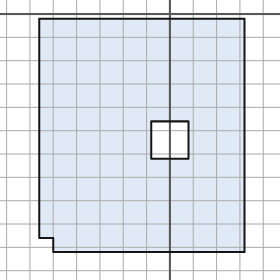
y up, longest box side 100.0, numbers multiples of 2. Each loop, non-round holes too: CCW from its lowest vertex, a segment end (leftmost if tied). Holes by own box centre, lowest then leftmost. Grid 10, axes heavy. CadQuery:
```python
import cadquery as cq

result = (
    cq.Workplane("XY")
    .moveTo(-50.0, -102.0)
    .lineTo(32.0, -102.0)
    .lineTo(32.0, -2.0)
    .lineTo(-56.0, -2.0)
    .lineTo(-56.0, -96.0)
    .lineTo(-50.0, -96.0)
    .close()
    .moveTo(-8.0, -62.0)
    .lineTo(8.0, -62.0)
    .lineTo(8.0, -46.0)
    .lineTo(-8.0, -46.0)
    .close()
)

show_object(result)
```